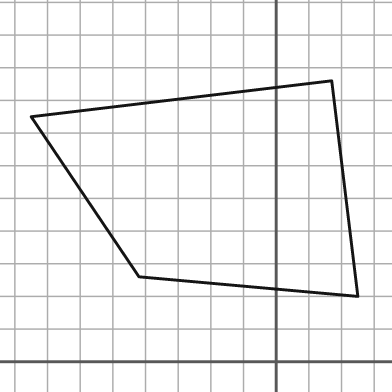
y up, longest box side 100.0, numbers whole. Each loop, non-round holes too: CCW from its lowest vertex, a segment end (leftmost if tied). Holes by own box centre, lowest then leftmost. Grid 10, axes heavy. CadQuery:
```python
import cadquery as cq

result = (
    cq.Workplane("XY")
    .moveTo(25.0, 20.0)
    .lineTo(17.0, 86.0)
    .lineTo(-75.0, 75.0)
    .lineTo(-42.0, 26.0)
    .close()
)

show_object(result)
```